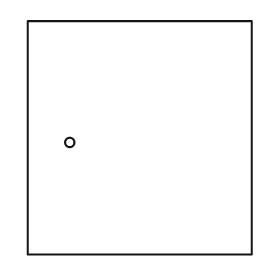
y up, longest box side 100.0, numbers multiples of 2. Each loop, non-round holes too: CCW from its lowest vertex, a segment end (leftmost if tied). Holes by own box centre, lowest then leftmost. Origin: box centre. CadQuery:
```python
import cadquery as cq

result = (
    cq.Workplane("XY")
    .moveTo(-48.0, -50.0)
    .lineTo(48.0, -50.0)
    .lineTo(48.0, 50.0)
    .lineTo(-48.0, 50.0)
    .close()
    .moveTo(-30.0, -2.0)
    .circle(2.0)
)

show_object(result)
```